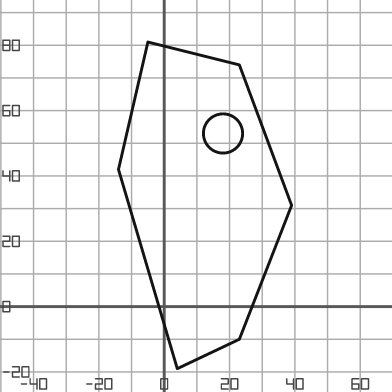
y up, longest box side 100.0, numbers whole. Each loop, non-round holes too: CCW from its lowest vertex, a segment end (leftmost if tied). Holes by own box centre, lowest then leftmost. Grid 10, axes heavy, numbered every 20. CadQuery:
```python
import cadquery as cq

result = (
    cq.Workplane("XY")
    .moveTo(4.0, -19.0)
    .lineTo(23.0, -10.0)
    .lineTo(39.0, 31.0)
    .lineTo(23.0, 74.0)
    .lineTo(-5.0, 81.0)
    .lineTo(-14.0, 42.0)
    .close()
    .moveTo(18.0, 53.0)
    .circle(6.0)
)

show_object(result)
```